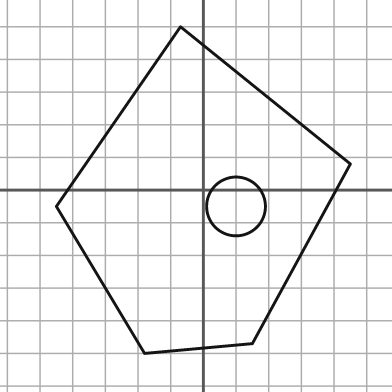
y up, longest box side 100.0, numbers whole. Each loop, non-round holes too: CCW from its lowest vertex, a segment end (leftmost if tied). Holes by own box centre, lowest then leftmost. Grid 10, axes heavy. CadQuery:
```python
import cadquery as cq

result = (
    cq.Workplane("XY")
    .moveTo(-18.0, -50.0)
    .lineTo(15.0, -47.0)
    .lineTo(45.0, 8.0)
    .lineTo(-7.0, 50.0)
    .lineTo(-45.0, -5.0)
    .close()
    .moveTo(10.0, -5.0)
    .circle(9.0)
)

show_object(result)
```